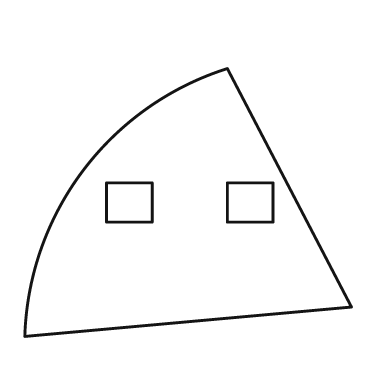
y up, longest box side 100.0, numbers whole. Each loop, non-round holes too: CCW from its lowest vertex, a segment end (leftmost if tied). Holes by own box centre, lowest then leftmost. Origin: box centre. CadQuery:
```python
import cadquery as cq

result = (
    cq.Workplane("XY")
    .moveTo(-50.0, -41.0)
    .lineTo(50.0, -32.0)
    .lineTo(12.0, 41.0)
    .threePointArc((-32.0, 10.0), (-50.0, -41.0))
    .close()
    .moveTo(-25.0, -6.0)
    .lineTo(-11.0, -6.0)
    .lineTo(-11.0, 6.0)
    .lineTo(-25.0, 6.0)
    .close()
    .moveTo(12.0, -6.0)
    .lineTo(26.0, -6.0)
    .lineTo(26.0, 6.0)
    .lineTo(12.0, 6.0)
    .close()
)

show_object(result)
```